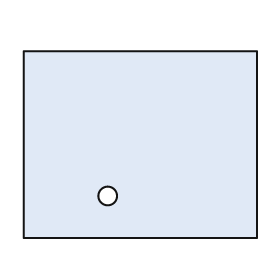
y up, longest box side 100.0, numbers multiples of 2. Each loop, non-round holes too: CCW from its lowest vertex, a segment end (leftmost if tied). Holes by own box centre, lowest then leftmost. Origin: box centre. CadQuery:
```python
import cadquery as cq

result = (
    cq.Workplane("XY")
    .moveTo(-50.0, -40.0)
    .lineTo(50.0, -40.0)
    .lineTo(50.0, 40.0)
    .lineTo(-50.0, 40.0)
    .close()
    .moveTo(-14.0, -22.0)
    .circle(4.0)
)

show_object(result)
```